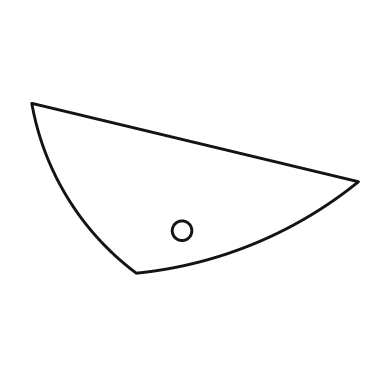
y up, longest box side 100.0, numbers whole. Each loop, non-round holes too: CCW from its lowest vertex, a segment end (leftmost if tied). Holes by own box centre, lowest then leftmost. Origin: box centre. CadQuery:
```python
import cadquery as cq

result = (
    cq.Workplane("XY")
    .moveTo(-18.0, -26.0)
    .threePointArc((18.0, -17.0), (50.0, 2.0))
    .lineTo(-50.0, 26.0)
    .threePointArc((-39.0, -3.0), (-18.0, -26.0))
    .close()
    .moveTo(-4.0, -13.0)
    .circle(3.0)
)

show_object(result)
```